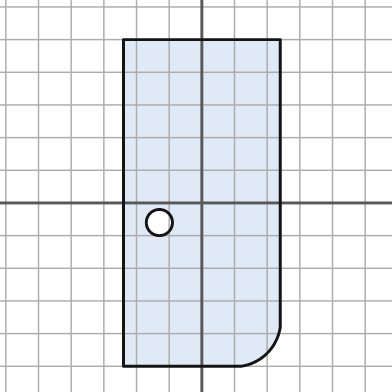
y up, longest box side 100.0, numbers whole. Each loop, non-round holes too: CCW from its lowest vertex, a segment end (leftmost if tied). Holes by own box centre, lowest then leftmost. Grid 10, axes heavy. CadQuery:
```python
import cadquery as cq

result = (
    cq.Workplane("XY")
    .moveTo(-24.0, -50.0)
    .lineTo(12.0, -50.0)
    .threePointArc((20.0, -46.0), (24.0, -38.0))
    .lineTo(24.0, 50.0)
    .lineTo(-24.0, 50.0)
    .close()
    .moveTo(-13.0, -6.0)
    .circle(4.0)
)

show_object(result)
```